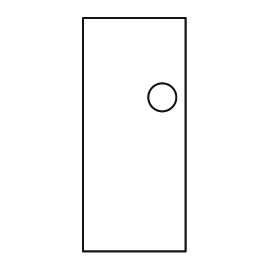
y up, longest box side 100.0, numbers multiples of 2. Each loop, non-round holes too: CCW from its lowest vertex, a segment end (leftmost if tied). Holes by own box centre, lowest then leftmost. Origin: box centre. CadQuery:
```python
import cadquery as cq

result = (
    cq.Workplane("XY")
    .moveTo(-22.0, -50.0)
    .lineTo(22.0, -50.0)
    .lineTo(22.0, 50.0)
    .lineTo(-22.0, 50.0)
    .close()
    .moveTo(12.0, 16.0)
    .circle(6.0)
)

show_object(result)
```